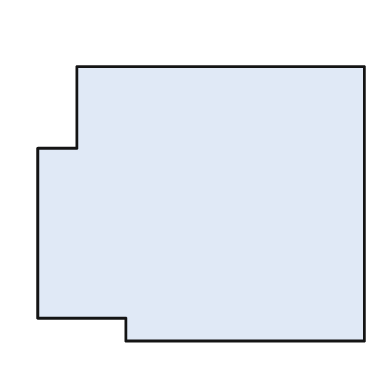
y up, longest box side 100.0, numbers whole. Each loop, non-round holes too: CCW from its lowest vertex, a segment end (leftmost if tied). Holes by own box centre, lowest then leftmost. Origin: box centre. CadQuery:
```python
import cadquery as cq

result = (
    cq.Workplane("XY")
    .moveTo(-23.0, -42.0)
    .lineTo(50.0, -42.0)
    .lineTo(50.0, 42.0)
    .lineTo(-38.0, 42.0)
    .lineTo(-38.0, 17.0)
    .lineTo(-50.0, 17.0)
    .lineTo(-50.0, -35.0)
    .lineTo(-23.0, -35.0)
    .close()
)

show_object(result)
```